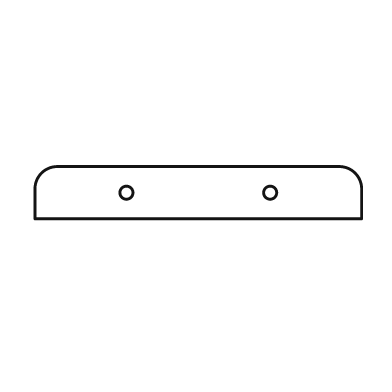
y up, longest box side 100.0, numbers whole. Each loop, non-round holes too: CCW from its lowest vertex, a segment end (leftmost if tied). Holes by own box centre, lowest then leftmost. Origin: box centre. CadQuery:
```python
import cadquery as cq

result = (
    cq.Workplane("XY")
    .moveTo(-50.0, -8.0)
    .lineTo(50.0, -8.0)
    .lineTo(50.0, 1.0)
    .threePointArc((48.0, 6.0), (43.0, 8.0))
    .lineTo(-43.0, 8.0)
    .threePointArc((-48.0, 6.0), (-50.0, 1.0))
    .close()
    .moveTo(-22.0, 0.0)
    .circle(2.0)
    .moveTo(22.0, 0.0)
    .circle(2.0)
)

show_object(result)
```